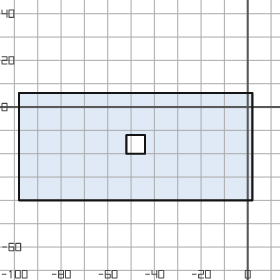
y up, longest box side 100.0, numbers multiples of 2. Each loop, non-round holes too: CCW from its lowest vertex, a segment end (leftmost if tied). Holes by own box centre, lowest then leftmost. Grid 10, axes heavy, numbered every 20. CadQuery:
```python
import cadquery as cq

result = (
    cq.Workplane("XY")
    .moveTo(-98.0, -40.0)
    .lineTo(2.0, -40.0)
    .lineTo(2.0, 6.0)
    .lineTo(-98.0, 6.0)
    .close()
    .moveTo(-52.0, -20.0)
    .lineTo(-44.0, -20.0)
    .lineTo(-44.0, -12.0)
    .lineTo(-52.0, -12.0)
    .close()
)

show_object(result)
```